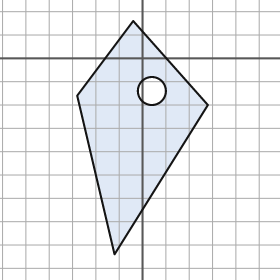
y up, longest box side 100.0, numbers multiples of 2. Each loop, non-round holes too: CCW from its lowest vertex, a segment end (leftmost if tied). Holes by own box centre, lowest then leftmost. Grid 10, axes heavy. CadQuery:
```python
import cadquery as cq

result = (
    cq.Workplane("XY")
    .moveTo(-12.0, -84.0)
    .lineTo(28.0, -20.0)
    .lineTo(-4.0, 16.0)
    .lineTo(-28.0, -16.0)
    .close()
    .moveTo(4.0, -14.0)
    .circle(6.0)
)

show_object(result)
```